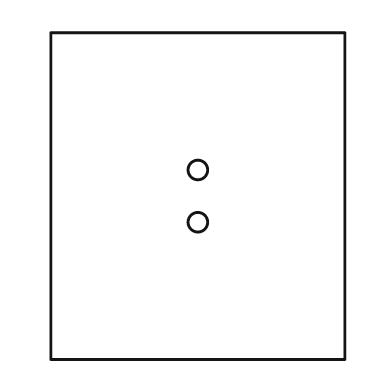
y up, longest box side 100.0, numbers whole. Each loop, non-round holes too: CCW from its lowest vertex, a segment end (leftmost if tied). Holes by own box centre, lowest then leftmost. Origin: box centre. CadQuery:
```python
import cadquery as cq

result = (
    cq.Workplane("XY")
    .moveTo(-45.0, -50.0)
    .lineTo(45.0, -50.0)
    .lineTo(45.0, 50.0)
    .lineTo(-45.0, 50.0)
    .close()
    .moveTo(0.0, -8.0)
    .circle(3.0)
    .moveTo(0.0, 8.0)
    .circle(3.0)
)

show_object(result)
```